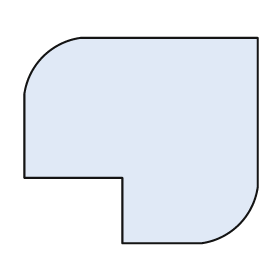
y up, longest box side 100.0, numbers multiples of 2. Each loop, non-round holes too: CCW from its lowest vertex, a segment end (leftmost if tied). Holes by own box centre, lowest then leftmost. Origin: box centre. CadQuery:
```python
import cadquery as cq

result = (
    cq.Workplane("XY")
    .moveTo(-8.0, -44.0)
    .lineTo(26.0, -44.0)
    .threePointArc((42.0, -36.0), (50.0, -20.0))
    .lineTo(50.0, 44.0)
    .lineTo(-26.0, 44.0)
    .threePointArc((-42.0, 36.0), (-50.0, 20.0))
    .lineTo(-50.0, -16.0)
    .lineTo(-8.0, -16.0)
    .close()
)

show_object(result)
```